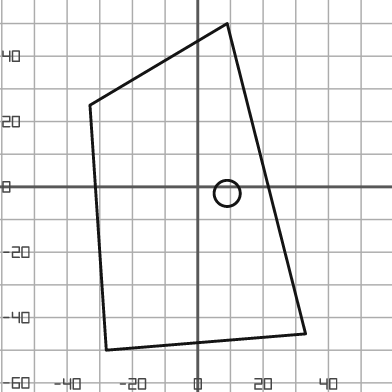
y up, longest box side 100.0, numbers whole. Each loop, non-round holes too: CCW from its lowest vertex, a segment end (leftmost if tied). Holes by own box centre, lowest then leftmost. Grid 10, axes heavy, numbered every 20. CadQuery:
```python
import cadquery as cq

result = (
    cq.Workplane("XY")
    .moveTo(-28.0, -50.0)
    .lineTo(33.0, -45.0)
    .lineTo(9.0, 50.0)
    .lineTo(-33.0, 25.0)
    .close()
    .moveTo(9.0, -2.0)
    .circle(4.0)
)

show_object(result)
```